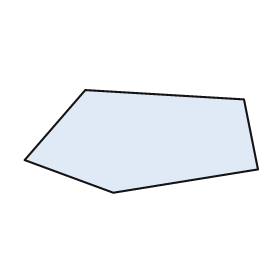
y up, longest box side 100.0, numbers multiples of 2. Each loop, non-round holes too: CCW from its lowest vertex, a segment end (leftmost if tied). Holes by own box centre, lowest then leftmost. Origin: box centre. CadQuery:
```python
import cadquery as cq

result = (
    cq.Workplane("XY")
    .moveTo(-12.0, -22.0)
    .lineTo(50.0, -12.0)
    .lineTo(44.0, 18.0)
    .lineTo(-24.0, 22.0)
    .lineTo(-50.0, -8.0)
    .close()
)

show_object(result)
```